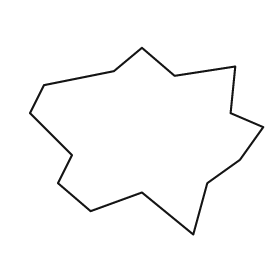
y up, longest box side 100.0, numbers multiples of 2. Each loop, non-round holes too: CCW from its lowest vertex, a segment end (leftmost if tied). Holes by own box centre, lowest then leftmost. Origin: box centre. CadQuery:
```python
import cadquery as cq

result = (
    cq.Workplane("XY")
    .moveTo(20.0, -40.0)
    .lineTo(26.0, -18.0)
    .lineTo(40.0, -8.0)
    .lineTo(50.0, 6.0)
    .lineTo(36.0, 12.0)
    .lineTo(38.0, 32.0)
    .lineTo(12.0, 28.0)
    .lineTo(-2.0, 40.0)
    .lineTo(-14.0, 30.0)
    .lineTo(-44.0, 24.0)
    .lineTo(-50.0, 12.0)
    .lineTo(-32.0, -6.0)
    .lineTo(-38.0, -18.0)
    .lineTo(-24.0, -30.0)
    .lineTo(-2.0, -22.0)
    .close()
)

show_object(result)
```